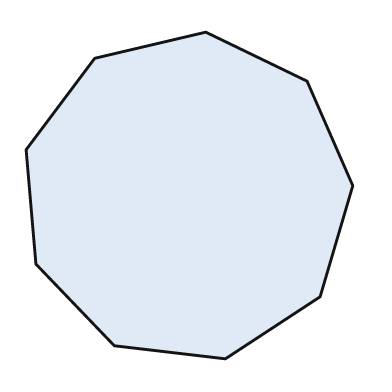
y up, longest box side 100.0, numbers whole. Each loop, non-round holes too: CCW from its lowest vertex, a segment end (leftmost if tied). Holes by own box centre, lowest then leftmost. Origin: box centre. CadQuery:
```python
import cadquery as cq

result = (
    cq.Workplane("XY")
    .moveTo(11.0, -50.0)
    .lineTo(40.0, -31.0)
    .lineTo(50.0, 3.0)
    .lineTo(36.0, 35.0)
    .lineTo(5.0, 50.0)
    .lineTo(-29.0, 42.0)
    .lineTo(-50.0, 14.0)
    .lineTo(-47.0, -21.0)
    .lineTo(-23.0, -46.0)
    .close()
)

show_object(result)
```